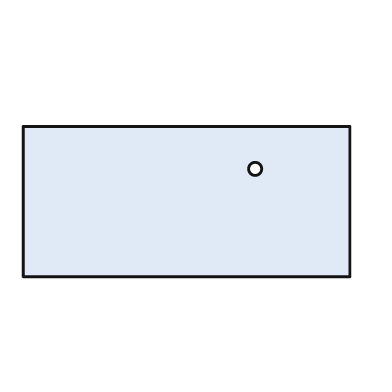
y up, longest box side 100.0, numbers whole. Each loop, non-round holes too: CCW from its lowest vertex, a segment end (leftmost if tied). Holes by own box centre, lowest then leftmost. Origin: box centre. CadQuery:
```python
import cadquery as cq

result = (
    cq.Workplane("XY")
    .moveTo(-50.0, -23.0)
    .lineTo(50.0, -23.0)
    .lineTo(50.0, 23.0)
    .lineTo(-50.0, 23.0)
    .close()
    .moveTo(21.0, 10.0)
    .circle(2.0)
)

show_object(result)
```